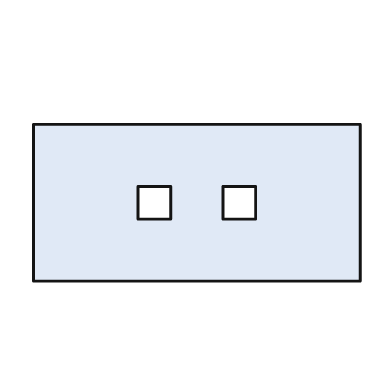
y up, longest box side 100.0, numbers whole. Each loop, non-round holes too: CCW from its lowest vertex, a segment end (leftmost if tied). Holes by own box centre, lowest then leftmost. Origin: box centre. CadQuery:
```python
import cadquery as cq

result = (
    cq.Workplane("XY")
    .moveTo(-50.0, -24.0)
    .lineTo(50.0, -24.0)
    .lineTo(50.0, 24.0)
    .lineTo(-50.0, 24.0)
    .close()
    .moveTo(-18.0, -5.0)
    .lineTo(-8.0, -5.0)
    .lineTo(-8.0, 5.0)
    .lineTo(-18.0, 5.0)
    .close()
    .moveTo(8.0, -5.0)
    .lineTo(18.0, -5.0)
    .lineTo(18.0, 5.0)
    .lineTo(8.0, 5.0)
    .close()
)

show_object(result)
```